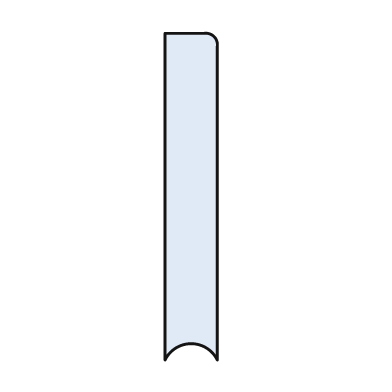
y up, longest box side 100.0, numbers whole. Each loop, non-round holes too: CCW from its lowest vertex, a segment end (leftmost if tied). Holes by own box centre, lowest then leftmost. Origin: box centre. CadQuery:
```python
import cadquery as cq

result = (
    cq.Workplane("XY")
    .moveTo(-8.0, -50.0)
    .threePointArc((0.0, -45.0), (8.0, -50.0))
    .lineTo(8.0, 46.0)
    .threePointArc((7.0, 49.0), (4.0, 50.0))
    .lineTo(-8.0, 50.0)
    .close()
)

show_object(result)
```